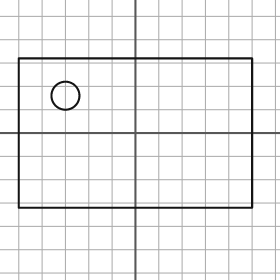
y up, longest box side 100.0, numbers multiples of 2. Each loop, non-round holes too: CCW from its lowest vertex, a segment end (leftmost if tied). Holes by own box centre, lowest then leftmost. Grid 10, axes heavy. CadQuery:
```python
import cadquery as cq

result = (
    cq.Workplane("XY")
    .moveTo(-50.0, -32.0)
    .lineTo(50.0, -32.0)
    .lineTo(50.0, 32.0)
    .lineTo(-50.0, 32.0)
    .close()
    .moveTo(-30.0, 16.0)
    .circle(6.0)
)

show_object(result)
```